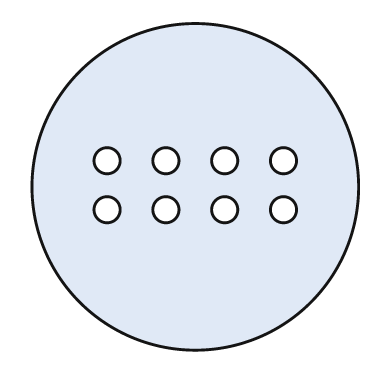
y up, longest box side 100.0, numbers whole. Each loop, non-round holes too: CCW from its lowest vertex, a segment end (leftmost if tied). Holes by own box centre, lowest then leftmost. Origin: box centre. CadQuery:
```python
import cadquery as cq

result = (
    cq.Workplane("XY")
    .moveTo(0.0, 0.0)
    .circle(50.0)
    .moveTo(-27.0, -7.0)
    .circle(4.0)
    .moveTo(-9.0, -7.0)
    .circle(4.0)
    .moveTo(9.0, -7.0)
    .circle(4.0)
    .moveTo(27.0, -7.0)
    .circle(4.0)
    .moveTo(-27.0, 8.0)
    .circle(4.0)
    .moveTo(-9.0, 8.0)
    .circle(4.0)
    .moveTo(9.0, 8.0)
    .circle(4.0)
    .moveTo(27.0, 8.0)
    .circle(4.0)
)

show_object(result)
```